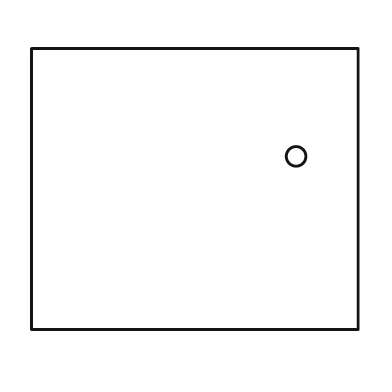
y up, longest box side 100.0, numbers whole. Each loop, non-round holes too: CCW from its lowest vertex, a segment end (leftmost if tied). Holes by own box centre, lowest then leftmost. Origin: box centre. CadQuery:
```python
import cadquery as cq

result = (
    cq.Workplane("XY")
    .moveTo(-50.0, -43.0)
    .lineTo(50.0, -43.0)
    .lineTo(50.0, 43.0)
    .lineTo(-50.0, 43.0)
    .close()
    .moveTo(31.0, 10.0)
    .circle(3.0)
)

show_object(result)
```